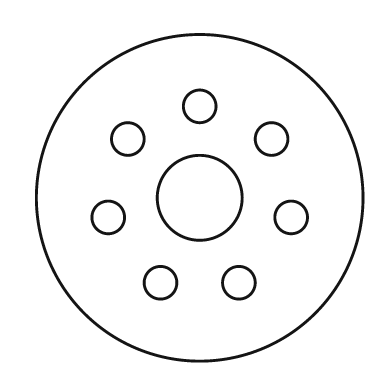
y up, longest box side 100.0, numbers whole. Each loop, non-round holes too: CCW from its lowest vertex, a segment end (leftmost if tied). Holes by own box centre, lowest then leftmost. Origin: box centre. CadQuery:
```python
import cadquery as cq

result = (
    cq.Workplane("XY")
    .moveTo(0.0, 0.0)
    .circle(50.0)
    .moveTo(-12.0, -26.0)
    .circle(5.0)
    .moveTo(12.0, -26.0)
    .circle(5.0)
    .moveTo(-28.0, -6.0)
    .circle(5.0)
    .moveTo(28.0, -6.0)
    .circle(5.0)
    .moveTo(0.0, 0.0)
    .circle(13.0)
    .moveTo(-22.0, 18.0)
    .circle(5.0)
    .moveTo(22.0, 18.0)
    .circle(5.0)
    .moveTo(0.0, 28.0)
    .circle(5.0)
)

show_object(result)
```